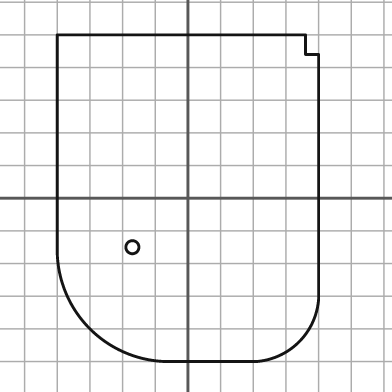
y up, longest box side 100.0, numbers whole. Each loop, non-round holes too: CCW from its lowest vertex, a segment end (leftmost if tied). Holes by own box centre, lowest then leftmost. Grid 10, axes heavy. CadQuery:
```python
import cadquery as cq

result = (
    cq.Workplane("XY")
    .moveTo(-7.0, -50.0)
    .lineTo(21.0, -50.0)
    .threePointArc((34.0, -44.0), (40.0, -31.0))
    .lineTo(40.0, 44.0)
    .lineTo(36.0, 44.0)
    .lineTo(36.0, 50.0)
    .lineTo(-40.0, 50.0)
    .lineTo(-40.0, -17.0)
    .threePointArc((-30.0, -40.0), (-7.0, -50.0))
    .close()
    .moveTo(-17.0, -15.0)
    .circle(2.0)
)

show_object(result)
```